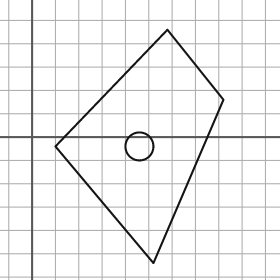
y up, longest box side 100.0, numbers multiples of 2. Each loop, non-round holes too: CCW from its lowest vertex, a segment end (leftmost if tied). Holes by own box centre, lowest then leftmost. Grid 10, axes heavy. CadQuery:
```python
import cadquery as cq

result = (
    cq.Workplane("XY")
    .moveTo(52.0, -54.0)
    .lineTo(82.0, 16.0)
    .lineTo(58.0, 46.0)
    .lineTo(10.0, -4.0)
    .close()
    .moveTo(46.0, -4.0)
    .circle(6.0)
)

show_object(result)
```